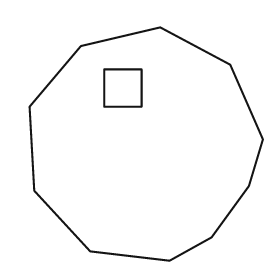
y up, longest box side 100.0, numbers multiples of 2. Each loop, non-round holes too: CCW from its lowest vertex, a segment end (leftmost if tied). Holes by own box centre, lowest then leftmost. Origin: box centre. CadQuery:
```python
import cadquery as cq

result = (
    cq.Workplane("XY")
    .moveTo(10.0, -50.0)
    .lineTo(28.0, -40.0)
    .lineTo(44.0, -18.0)
    .lineTo(50.0, 2.0)
    .lineTo(36.0, 34.0)
    .lineTo(6.0, 50.0)
    .lineTo(-28.0, 42.0)
    .lineTo(-50.0, 16.0)
    .lineTo(-48.0, -20.0)
    .lineTo(-24.0, -46.0)
    .close()
    .moveTo(-18.0, 16.0)
    .lineTo(-2.0, 16.0)
    .lineTo(-2.0, 32.0)
    .lineTo(-18.0, 32.0)
    .close()
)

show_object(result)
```